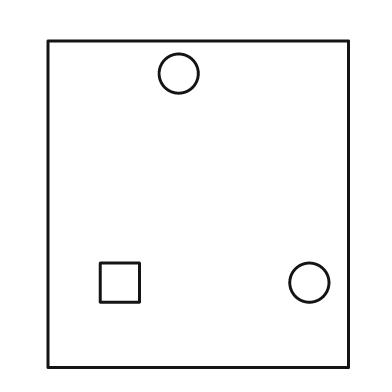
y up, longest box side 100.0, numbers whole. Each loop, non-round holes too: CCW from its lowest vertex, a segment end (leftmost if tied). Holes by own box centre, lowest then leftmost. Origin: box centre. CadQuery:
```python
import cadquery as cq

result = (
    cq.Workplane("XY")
    .moveTo(-46.0, -50.0)
    .lineTo(46.0, -50.0)
    .lineTo(46.0, 50.0)
    .lineTo(-46.0, 50.0)
    .close()
    .moveTo(-30.0, -30.0)
    .lineTo(-18.0, -30.0)
    .lineTo(-18.0, -18.0)
    .lineTo(-30.0, -18.0)
    .close()
    .moveTo(34.0, -24.0)
    .circle(6.0)
    .moveTo(-6.0, 40.0)
    .circle(6.0)
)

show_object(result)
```